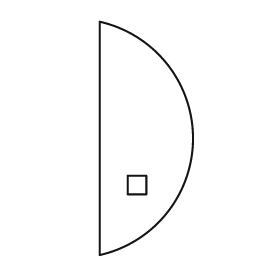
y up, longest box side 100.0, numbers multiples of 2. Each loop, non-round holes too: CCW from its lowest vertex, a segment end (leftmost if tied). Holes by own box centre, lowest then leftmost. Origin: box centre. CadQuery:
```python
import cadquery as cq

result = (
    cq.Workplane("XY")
    .moveTo(-20.0, -50.0)
    .threePointArc((20.0, 0.0), (-20.0, 50.0))
    .close()
    .moveTo(-8.0, -24.0)
    .lineTo(0.0, -24.0)
    .lineTo(0.0, -16.0)
    .lineTo(-8.0, -16.0)
    .close()
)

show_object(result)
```